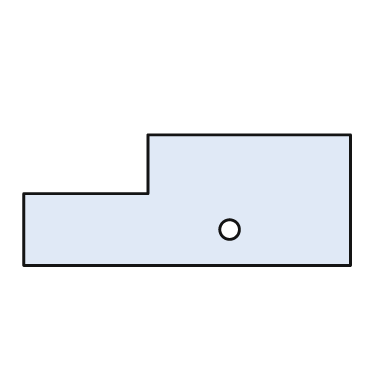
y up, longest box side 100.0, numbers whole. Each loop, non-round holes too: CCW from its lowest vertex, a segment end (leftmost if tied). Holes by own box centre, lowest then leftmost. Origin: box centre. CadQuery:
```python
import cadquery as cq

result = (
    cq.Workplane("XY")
    .moveTo(-50.0, -20.0)
    .lineTo(50.0, -20.0)
    .lineTo(50.0, 20.0)
    .lineTo(-12.0, 20.0)
    .lineTo(-12.0, 2.0)
    .lineTo(-50.0, 2.0)
    .close()
    .moveTo(13.0, -9.0)
    .circle(3.0)
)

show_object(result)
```